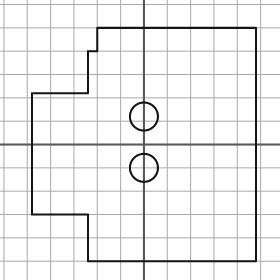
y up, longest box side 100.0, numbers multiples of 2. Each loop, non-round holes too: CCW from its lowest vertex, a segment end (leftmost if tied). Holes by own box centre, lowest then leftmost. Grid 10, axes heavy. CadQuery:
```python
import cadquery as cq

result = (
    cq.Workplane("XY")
    .moveTo(-24.0, -50.0)
    .lineTo(48.0, -50.0)
    .lineTo(48.0, 50.0)
    .lineTo(-20.0, 50.0)
    .lineTo(-20.0, 40.0)
    .lineTo(-24.0, 40.0)
    .lineTo(-24.0, 22.0)
    .lineTo(-48.0, 22.0)
    .lineTo(-48.0, -30.0)
    .lineTo(-24.0, -30.0)
    .close()
    .moveTo(0.0, -10.0)
    .circle(6.0)
    .moveTo(0.0, 12.0)
    .circle(6.0)
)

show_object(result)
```